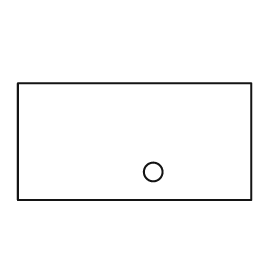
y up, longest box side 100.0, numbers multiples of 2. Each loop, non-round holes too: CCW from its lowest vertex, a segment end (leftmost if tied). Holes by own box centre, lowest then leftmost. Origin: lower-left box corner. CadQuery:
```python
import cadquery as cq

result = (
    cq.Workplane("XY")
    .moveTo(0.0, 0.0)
    .lineTo(100.0, 0.0)
    .lineTo(100.0, 50.0)
    .lineTo(0.0, 50.0)
    .close()
    .moveTo(58.0, 12.0)
    .circle(4.0)
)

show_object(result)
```